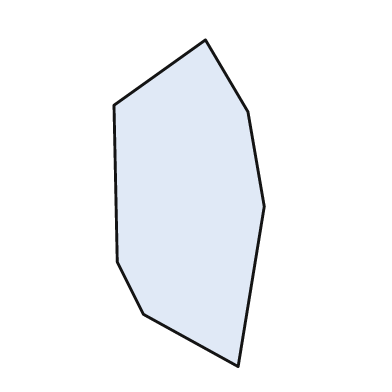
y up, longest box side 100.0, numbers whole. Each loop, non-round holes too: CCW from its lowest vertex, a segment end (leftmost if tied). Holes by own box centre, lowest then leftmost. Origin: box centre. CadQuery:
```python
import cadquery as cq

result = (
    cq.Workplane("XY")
    .moveTo(15.0, -50.0)
    .lineTo(23.0, -1.0)
    .lineTo(18.0, 28.0)
    .lineTo(5.0, 50.0)
    .lineTo(-23.0, 30.0)
    .lineTo(-22.0, -18.0)
    .lineTo(-14.0, -34.0)
    .close()
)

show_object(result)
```